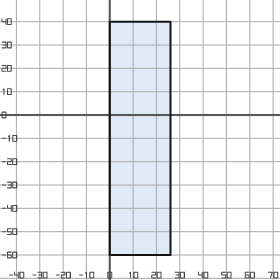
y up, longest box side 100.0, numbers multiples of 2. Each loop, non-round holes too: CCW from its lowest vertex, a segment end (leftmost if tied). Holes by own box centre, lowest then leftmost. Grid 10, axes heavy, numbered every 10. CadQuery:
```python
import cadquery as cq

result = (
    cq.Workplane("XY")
    .moveTo(0.0, -60.0)
    .lineTo(26.0, -60.0)
    .lineTo(26.0, 40.0)
    .lineTo(0.0, 40.0)
    .close()
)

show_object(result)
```